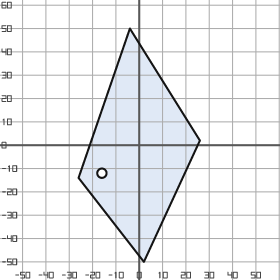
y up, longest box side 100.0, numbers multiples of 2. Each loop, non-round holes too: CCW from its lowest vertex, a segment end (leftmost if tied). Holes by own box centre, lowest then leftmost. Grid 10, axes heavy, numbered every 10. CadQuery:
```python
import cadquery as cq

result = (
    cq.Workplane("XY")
    .moveTo(2.0, -50.0)
    .lineTo(26.0, 2.0)
    .lineTo(-4.0, 50.0)
    .lineTo(-26.0, -14.0)
    .close()
    .moveTo(-16.0, -12.0)
    .circle(2.0)
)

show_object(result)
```